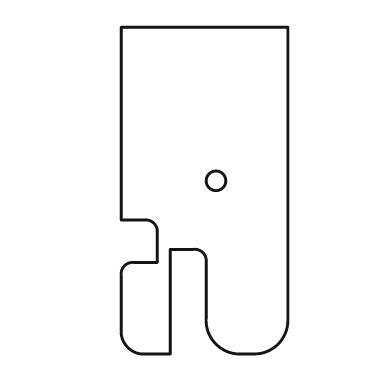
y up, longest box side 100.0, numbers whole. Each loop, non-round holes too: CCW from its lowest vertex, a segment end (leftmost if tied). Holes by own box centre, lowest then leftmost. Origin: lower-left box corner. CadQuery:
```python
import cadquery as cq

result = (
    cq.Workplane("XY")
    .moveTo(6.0, 0.0)
    .lineTo(15.0, 0.0)
    .lineTo(15.0, 32.0)
    .lineTo(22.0, 32.0)
    .threePointArc((25.0, 31.0), (26.0, 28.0))
    .lineTo(26.0, 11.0)
    .threePointArc((29.0, 3.0), (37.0, 0.0))
    .lineTo(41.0, 0.0)
    .threePointArc((48.0, 3.0), (51.0, 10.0))
    .lineTo(51.0, 100.0)
    .lineTo(0.0, 100.0)
    .lineTo(0.0, 41.0)
    .lineTo(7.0, 41.0)
    .threePointArc((10.0, 40.0), (11.0, 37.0))
    .lineTo(11.0, 28.0)
    .lineTo(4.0, 28.0)
    .threePointArc((1.0, 27.0), (0.0, 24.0))
    .lineTo(0.0, 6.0)
    .threePointArc((2.0, 2.0), (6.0, 0.0))
    .close()
    .moveTo(29.0, 53.0)
    .circle(3.0)
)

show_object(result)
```